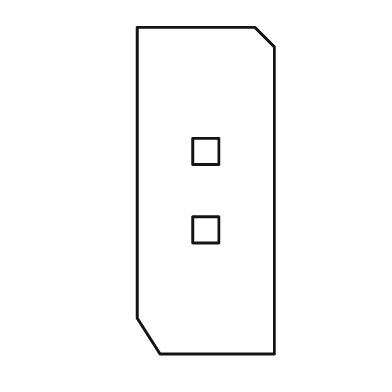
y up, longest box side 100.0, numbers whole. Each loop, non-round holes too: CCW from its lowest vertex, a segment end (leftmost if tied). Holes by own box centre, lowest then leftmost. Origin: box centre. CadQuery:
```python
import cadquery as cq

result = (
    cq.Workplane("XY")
    .moveTo(-14.0, -50.0)
    .lineTo(21.0, -50.0)
    .lineTo(21.0, 44.0)
    .lineTo(15.0, 50.0)
    .lineTo(-21.0, 50.0)
    .lineTo(-21.0, -39.0)
    .close()
    .moveTo(-4.0, -16.0)
    .lineTo(4.0, -16.0)
    .lineTo(4.0, -8.0)
    .lineTo(-4.0, -8.0)
    .close()
    .moveTo(-4.0, 8.0)
    .lineTo(4.0, 8.0)
    .lineTo(4.0, 16.0)
    .lineTo(-4.0, 16.0)
    .close()
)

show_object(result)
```